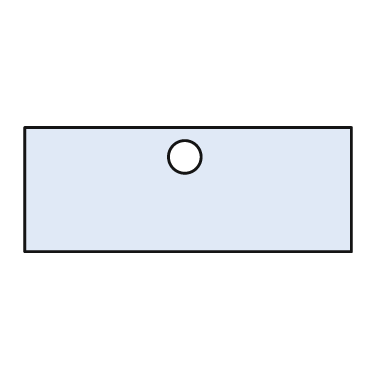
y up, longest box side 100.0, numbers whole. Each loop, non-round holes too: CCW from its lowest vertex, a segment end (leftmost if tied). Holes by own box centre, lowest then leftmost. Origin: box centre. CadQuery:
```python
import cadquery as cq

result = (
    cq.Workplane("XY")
    .moveTo(-50.0, -19.0)
    .lineTo(50.0, -19.0)
    .lineTo(50.0, 19.0)
    .lineTo(-50.0, 19.0)
    .close()
    .moveTo(-1.0, 10.0)
    .circle(5.0)
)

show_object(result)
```